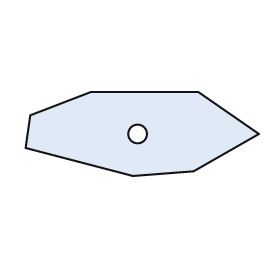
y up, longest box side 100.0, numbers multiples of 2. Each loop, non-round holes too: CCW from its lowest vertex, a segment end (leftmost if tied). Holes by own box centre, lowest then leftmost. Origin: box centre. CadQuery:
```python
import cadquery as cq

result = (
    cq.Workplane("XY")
    .moveTo(-4.0, -18.0)
    .lineTo(22.0, -16.0)
    .lineTo(50.0, 0.0)
    .lineTo(24.0, 18.0)
    .lineTo(-22.0, 18.0)
    .lineTo(-48.0, 8.0)
    .lineTo(-50.0, -6.0)
    .close()
    .moveTo(-2.0, 0.0)
    .circle(4.0)
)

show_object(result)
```